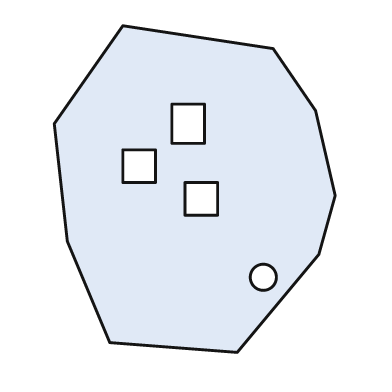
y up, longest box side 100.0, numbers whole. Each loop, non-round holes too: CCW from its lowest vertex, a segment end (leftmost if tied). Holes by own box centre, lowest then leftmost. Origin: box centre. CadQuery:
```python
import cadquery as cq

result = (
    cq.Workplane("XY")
    .moveTo(13.0, -50.0)
    .lineTo(38.0, -20.0)
    .lineTo(43.0, -2.0)
    .lineTo(37.0, 24.0)
    .lineTo(24.0, 43.0)
    .lineTo(-22.0, 50.0)
    .lineTo(-43.0, 20.0)
    .lineTo(-39.0, -16.0)
    .lineTo(-26.0, -47.0)
    .close()
    .moveTo(21.0, -27.0)
    .circle(4.0)
    .moveTo(-3.0, -8.0)
    .lineTo(7.0, -8.0)
    .lineTo(7.0, 2.0)
    .lineTo(-3.0, 2.0)
    .close()
    .moveTo(-22.0, 2.0)
    .lineTo(-12.0, 2.0)
    .lineTo(-12.0, 12.0)
    .lineTo(-22.0, 12.0)
    .close()
    .moveTo(-7.0, 14.0)
    .lineTo(3.0, 14.0)
    .lineTo(3.0, 26.0)
    .lineTo(-7.0, 26.0)
    .close()
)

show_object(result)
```